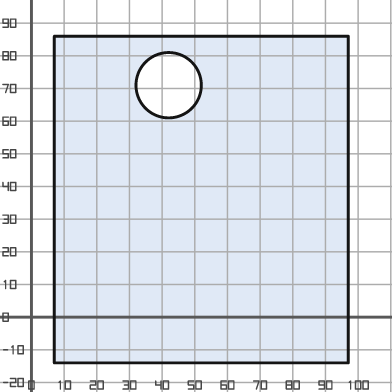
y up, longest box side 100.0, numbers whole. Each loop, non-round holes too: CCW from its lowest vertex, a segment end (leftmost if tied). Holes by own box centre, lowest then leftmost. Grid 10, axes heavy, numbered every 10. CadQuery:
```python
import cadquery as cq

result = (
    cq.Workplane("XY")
    .moveTo(7.0, -14.0)
    .lineTo(97.0, -14.0)
    .lineTo(97.0, 86.0)
    .lineTo(7.0, 86.0)
    .close()
    .moveTo(42.0, 71.0)
    .circle(10.0)
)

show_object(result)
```